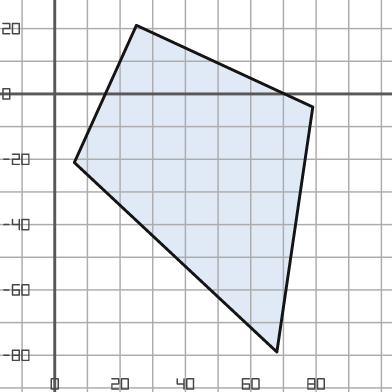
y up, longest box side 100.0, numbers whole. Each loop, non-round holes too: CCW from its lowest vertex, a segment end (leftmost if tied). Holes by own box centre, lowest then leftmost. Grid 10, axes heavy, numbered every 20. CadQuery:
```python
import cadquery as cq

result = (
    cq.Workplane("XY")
    .moveTo(68.0, -79.0)
    .lineTo(79.0, -4.0)
    .lineTo(25.0, 21.0)
    .lineTo(6.0, -21.0)
    .close()
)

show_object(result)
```